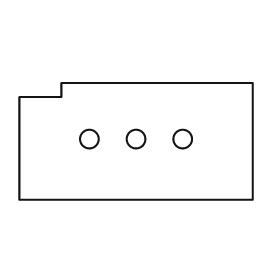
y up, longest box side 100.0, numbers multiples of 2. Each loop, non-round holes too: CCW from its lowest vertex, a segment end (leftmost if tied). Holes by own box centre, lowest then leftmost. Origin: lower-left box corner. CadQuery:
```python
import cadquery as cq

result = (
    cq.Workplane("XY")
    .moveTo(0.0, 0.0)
    .lineTo(100.0, 0.0)
    .lineTo(100.0, 50.0)
    .lineTo(18.0, 50.0)
    .lineTo(18.0, 44.0)
    .lineTo(0.0, 44.0)
    .close()
    .moveTo(30.0, 26.0)
    .circle(4.0)
    .moveTo(50.0, 26.0)
    .circle(4.0)
    .moveTo(70.0, 26.0)
    .circle(4.0)
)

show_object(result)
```